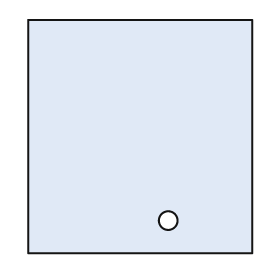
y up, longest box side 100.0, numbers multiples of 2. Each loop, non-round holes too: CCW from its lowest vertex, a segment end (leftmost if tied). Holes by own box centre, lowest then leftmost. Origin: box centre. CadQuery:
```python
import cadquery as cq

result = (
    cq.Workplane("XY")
    .moveTo(-48.0, -50.0)
    .lineTo(48.0, -50.0)
    .lineTo(48.0, 50.0)
    .lineTo(-48.0, 50.0)
    .close()
    .moveTo(12.0, -36.0)
    .circle(4.0)
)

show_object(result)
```